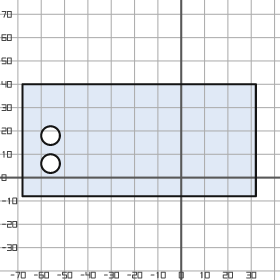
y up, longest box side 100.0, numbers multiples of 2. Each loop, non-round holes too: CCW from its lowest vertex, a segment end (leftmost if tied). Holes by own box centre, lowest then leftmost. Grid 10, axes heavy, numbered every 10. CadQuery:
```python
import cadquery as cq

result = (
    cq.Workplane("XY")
    .moveTo(-68.0, -8.0)
    .lineTo(32.0, -8.0)
    .lineTo(32.0, 40.0)
    .lineTo(-68.0, 40.0)
    .close()
    .moveTo(-56.0, 6.0)
    .circle(4.0)
    .moveTo(-56.0, 18.0)
    .circle(4.0)
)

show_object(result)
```